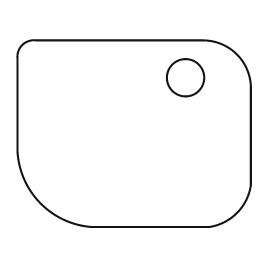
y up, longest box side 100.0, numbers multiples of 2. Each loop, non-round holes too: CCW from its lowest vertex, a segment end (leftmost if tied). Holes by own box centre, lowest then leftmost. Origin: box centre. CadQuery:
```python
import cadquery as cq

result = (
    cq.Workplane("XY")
    .moveTo(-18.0, -40.0)
    .lineTo(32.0, -40.0)
    .threePointArc((44.0, -34.0), (50.0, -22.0))
    .lineTo(50.0, 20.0)
    .threePointArc((44.0, 34.0), (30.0, 40.0))
    .lineTo(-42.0, 40.0)
    .threePointArc((-48.0, 38.0), (-50.0, 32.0))
    .lineTo(-50.0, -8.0)
    .threePointArc((-40.0, -30.0), (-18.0, -40.0))
    .close()
    .moveTo(22.0, 24.0)
    .circle(8.0)
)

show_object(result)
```